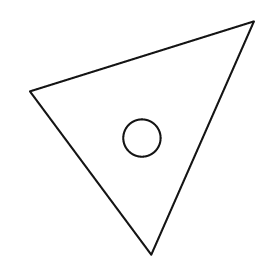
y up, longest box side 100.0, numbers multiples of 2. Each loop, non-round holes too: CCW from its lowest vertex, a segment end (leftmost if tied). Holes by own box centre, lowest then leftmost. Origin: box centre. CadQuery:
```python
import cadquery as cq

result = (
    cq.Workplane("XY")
    .moveTo(4.0, -50.0)
    .lineTo(48.0, 50.0)
    .lineTo(-48.0, 20.0)
    .close()
    .moveTo(0.0, 0.0)
    .circle(8.0)
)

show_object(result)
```